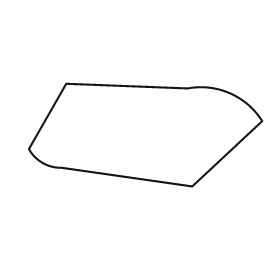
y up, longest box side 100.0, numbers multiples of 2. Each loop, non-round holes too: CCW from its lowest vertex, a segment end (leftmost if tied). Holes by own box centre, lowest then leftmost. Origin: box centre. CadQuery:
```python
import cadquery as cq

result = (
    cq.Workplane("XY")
    .moveTo(20.0, -22.0)
    .lineTo(50.0, 6.0)
    .threePointArc((36.0, 18.0), (18.0, 20.0))
    .lineTo(-34.0, 22.0)
    .lineTo(-50.0, -6.0)
    .threePointArc((-44.0, -12.0), (-36.0, -14.0))
    .close()
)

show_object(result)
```